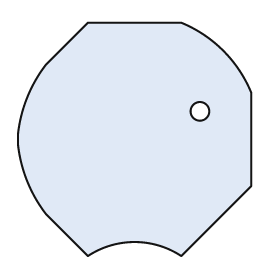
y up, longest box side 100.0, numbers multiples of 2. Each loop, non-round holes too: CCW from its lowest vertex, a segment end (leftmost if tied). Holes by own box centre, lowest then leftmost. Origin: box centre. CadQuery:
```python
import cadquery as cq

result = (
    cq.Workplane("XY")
    .moveTo(-20.0, -50.0)
    .threePointArc((0.0, -44.0), (20.0, -50.0))
    .lineTo(50.0, -20.0)
    .lineTo(50.0, 20.0)
    .threePointArc((38.0, 38.0), (20.0, 50.0))
    .lineTo(-20.0, 50.0)
    .lineTo(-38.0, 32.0)
    .threePointArc((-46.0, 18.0), (-50.0, 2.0))
    .lineTo(-50.0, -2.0)
    .threePointArc((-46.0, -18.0), (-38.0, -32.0))
    .close()
    .moveTo(28.0, 12.0)
    .circle(4.0)
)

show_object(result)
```